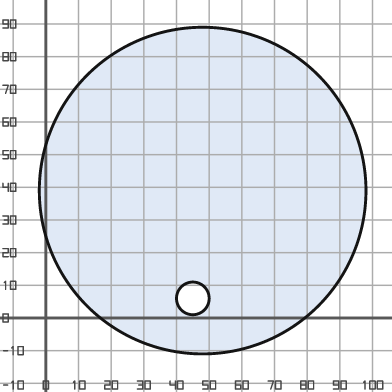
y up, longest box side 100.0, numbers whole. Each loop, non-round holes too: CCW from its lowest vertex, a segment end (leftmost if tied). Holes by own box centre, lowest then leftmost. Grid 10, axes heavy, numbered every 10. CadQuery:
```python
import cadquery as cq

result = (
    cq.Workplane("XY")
    .moveTo(48.0, 39.0)
    .circle(50.0)
    .moveTo(45.0, 6.0)
    .circle(5.0)
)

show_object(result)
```